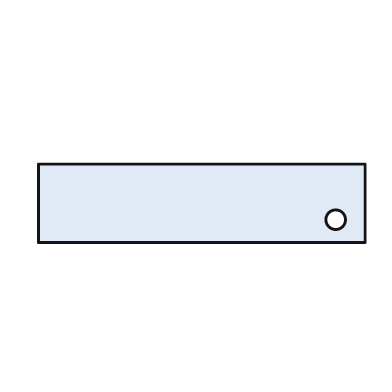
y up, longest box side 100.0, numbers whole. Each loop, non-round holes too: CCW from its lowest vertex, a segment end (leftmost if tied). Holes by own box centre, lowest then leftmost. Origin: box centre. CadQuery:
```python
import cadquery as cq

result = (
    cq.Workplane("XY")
    .moveTo(-50.0, -12.0)
    .lineTo(50.0, -12.0)
    .lineTo(50.0, 12.0)
    .lineTo(-50.0, 12.0)
    .close()
    .moveTo(41.0, -5.0)
    .circle(3.0)
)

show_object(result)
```